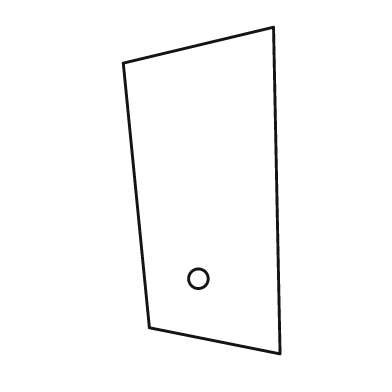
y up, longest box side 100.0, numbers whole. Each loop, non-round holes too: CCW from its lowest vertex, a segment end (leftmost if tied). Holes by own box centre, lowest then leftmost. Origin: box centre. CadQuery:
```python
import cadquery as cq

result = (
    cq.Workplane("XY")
    .moveTo(24.0, -50.0)
    .lineTo(22.0, 50.0)
    .lineTo(-24.0, 39.0)
    .lineTo(-16.0, -42.0)
    .close()
    .moveTo(-1.0, -27.0)
    .circle(3.0)
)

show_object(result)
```